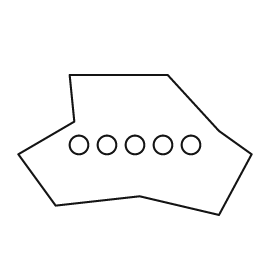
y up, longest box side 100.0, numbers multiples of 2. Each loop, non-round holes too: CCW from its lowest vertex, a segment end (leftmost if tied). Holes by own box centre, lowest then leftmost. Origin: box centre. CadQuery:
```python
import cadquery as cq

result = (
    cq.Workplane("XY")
    .moveTo(36.0, -30.0)
    .lineTo(50.0, -4.0)
    .lineTo(36.0, 6.0)
    .lineTo(14.0, 30.0)
    .lineTo(-28.0, 30.0)
    .lineTo(-26.0, 10.0)
    .lineTo(-50.0, -4.0)
    .lineTo(-34.0, -26.0)
    .lineTo(2.0, -22.0)
    .close()
    .moveTo(-24.0, 0.0)
    .circle(4.0)
    .moveTo(-12.0, 0.0)
    .circle(4.0)
    .moveTo(0.0, 0.0)
    .circle(4.0)
    .moveTo(12.0, 0.0)
    .circle(4.0)
    .moveTo(24.0, 0.0)
    .circle(4.0)
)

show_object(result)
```